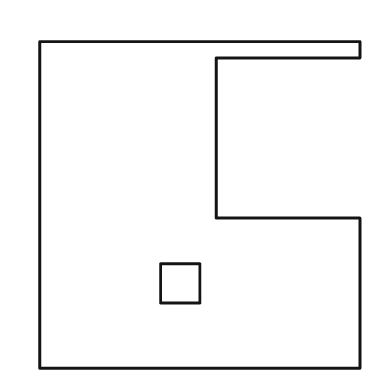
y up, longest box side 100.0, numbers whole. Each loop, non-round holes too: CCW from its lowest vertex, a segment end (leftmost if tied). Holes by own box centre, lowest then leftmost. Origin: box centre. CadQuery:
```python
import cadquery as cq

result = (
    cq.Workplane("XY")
    .moveTo(-49.0, -50.0)
    .lineTo(49.0, -50.0)
    .lineTo(49.0, -4.0)
    .lineTo(5.0, -4.0)
    .lineTo(5.0, 45.0)
    .lineTo(49.0, 45.0)
    .lineTo(49.0, 50.0)
    .lineTo(-49.0, 50.0)
    .close()
    .moveTo(-12.0, -30.0)
    .lineTo(0.0, -30.0)
    .lineTo(0.0, -18.0)
    .lineTo(-12.0, -18.0)
    .close()
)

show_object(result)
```